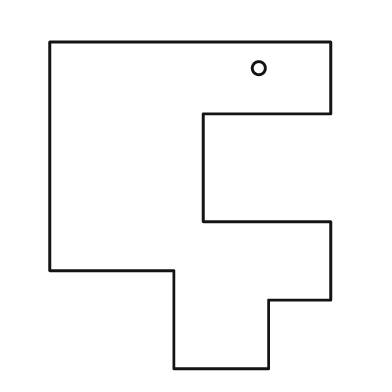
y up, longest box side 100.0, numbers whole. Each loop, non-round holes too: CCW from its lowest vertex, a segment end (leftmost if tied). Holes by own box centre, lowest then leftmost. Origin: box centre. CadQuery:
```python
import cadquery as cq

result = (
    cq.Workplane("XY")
    .moveTo(-5.0, -50.0)
    .lineTo(24.0, -50.0)
    .lineTo(24.0, -29.0)
    .lineTo(43.0, -29.0)
    .lineTo(43.0, -5.0)
    .lineTo(4.0, -5.0)
    .lineTo(4.0, 28.0)
    .lineTo(43.0, 28.0)
    .lineTo(43.0, 50.0)
    .lineTo(-43.0, 50.0)
    .lineTo(-43.0, -20.0)
    .lineTo(-5.0, -20.0)
    .close()
    .moveTo(21.0, 42.0)
    .circle(2.0)
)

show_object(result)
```